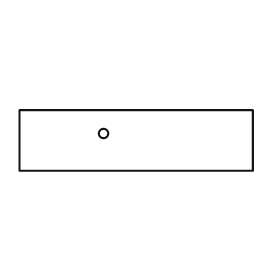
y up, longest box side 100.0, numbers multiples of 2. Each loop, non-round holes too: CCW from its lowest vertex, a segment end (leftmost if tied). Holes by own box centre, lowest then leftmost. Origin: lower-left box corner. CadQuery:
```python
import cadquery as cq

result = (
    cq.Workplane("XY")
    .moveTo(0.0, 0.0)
    .lineTo(100.0, 0.0)
    .lineTo(100.0, 26.0)
    .lineTo(0.0, 26.0)
    .close()
    .moveTo(36.0, 16.0)
    .circle(2.0)
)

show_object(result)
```